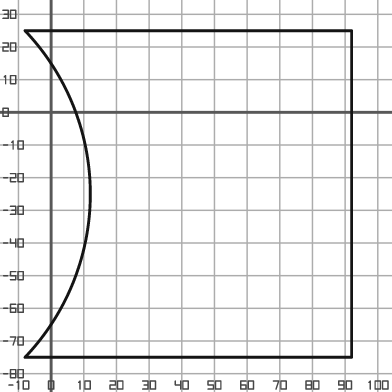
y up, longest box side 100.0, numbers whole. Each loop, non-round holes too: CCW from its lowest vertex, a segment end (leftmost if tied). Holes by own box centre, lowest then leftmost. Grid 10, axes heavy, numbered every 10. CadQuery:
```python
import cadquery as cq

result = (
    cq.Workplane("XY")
    .moveTo(-8.0, -75.0)
    .lineTo(92.0, -75.0)
    .lineTo(92.0, 25.0)
    .lineTo(-8.0, 25.0)
    .threePointArc((12.0, -25.0), (-8.0, -75.0))
    .close()
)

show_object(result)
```